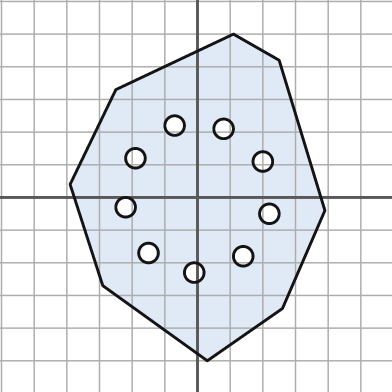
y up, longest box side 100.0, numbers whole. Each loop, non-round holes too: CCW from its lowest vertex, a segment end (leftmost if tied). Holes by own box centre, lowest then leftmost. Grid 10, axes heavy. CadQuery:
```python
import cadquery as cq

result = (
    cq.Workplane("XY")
    .moveTo(3.0, -50.0)
    .lineTo(26.0, -34.0)
    .lineTo(39.0, -4.0)
    .lineTo(25.0, 42.0)
    .lineTo(11.0, 50.0)
    .lineTo(-25.0, 33.0)
    .lineTo(-39.0, 4.0)
    .lineTo(-29.0, -27.0)
    .close()
    .moveTo(-1.0, -23.0)
    .circle(3.0)
    .moveTo(14.0, -18.0)
    .circle(3.0)
    .moveTo(-15.0, -17.0)
    .circle(3.0)
    .moveTo(22.0, -5.0)
    .circle(3.0)
    .moveTo(-22.0, -3.0)
    .circle(3.0)
    .moveTo(20.0, 11.0)
    .circle(3.0)
    .moveTo(-19.0, 12.0)
    .circle(3.0)
    .moveTo(8.0, 21.0)
    .circle(3.0)
    .moveTo(-7.0, 22.0)
    .circle(3.0)
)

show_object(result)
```